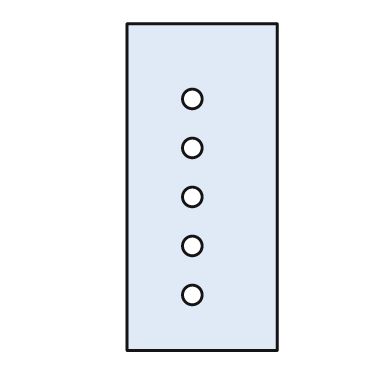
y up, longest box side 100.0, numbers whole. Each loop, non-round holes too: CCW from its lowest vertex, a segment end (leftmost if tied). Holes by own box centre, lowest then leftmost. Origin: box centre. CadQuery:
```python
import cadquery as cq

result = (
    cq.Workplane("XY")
    .moveTo(-23.0, -50.0)
    .lineTo(23.0, -50.0)
    .lineTo(23.0, 50.0)
    .lineTo(-23.0, 50.0)
    .close()
    .moveTo(-3.0, -33.0)
    .circle(3.0)
    .moveTo(-3.0, -18.0)
    .circle(3.0)
    .moveTo(-3.0, -3.0)
    .circle(3.0)
    .moveTo(-3.0, 12.0)
    .circle(3.0)
    .moveTo(-3.0, 27.0)
    .circle(3.0)
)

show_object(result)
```